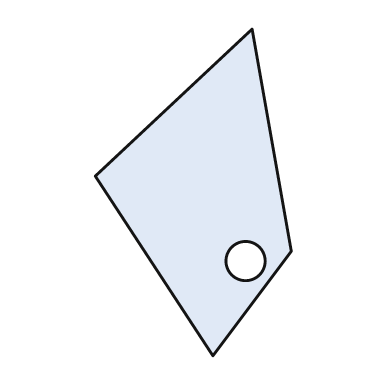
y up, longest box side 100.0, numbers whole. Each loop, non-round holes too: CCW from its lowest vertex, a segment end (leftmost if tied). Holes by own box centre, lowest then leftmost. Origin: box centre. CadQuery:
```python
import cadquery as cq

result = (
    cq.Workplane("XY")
    .moveTo(6.0, -50.0)
    .lineTo(30.0, -18.0)
    .lineTo(18.0, 50.0)
    .lineTo(-30.0, 5.0)
    .close()
    .moveTo(16.0, -21.0)
    .circle(6.0)
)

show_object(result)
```